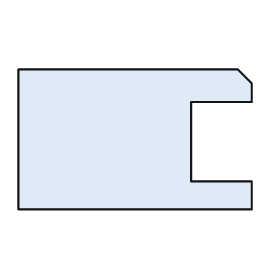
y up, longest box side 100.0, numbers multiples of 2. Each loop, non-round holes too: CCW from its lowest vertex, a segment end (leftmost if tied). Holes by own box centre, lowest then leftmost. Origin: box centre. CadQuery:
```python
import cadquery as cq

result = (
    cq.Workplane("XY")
    .moveTo(-50.0, -30.0)
    .lineTo(50.0, -30.0)
    .lineTo(50.0, -18.0)
    .lineTo(24.0, -18.0)
    .lineTo(24.0, 16.0)
    .lineTo(50.0, 16.0)
    .lineTo(50.0, 24.0)
    .lineTo(44.0, 30.0)
    .lineTo(-50.0, 30.0)
    .close()
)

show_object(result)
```